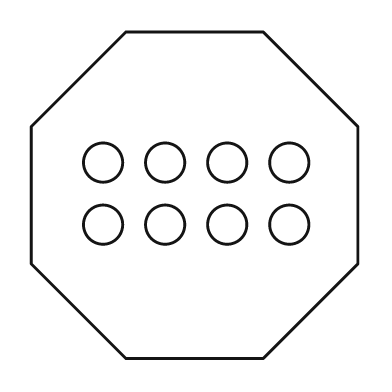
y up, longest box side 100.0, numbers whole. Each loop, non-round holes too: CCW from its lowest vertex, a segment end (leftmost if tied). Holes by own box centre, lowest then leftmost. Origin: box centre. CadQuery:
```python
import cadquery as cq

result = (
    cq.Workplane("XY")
    .moveTo(-21.0, -50.0)
    .lineTo(21.0, -50.0)
    .lineTo(50.0, -21.0)
    .lineTo(50.0, 21.0)
    .lineTo(21.0, 50.0)
    .lineTo(-21.0, 50.0)
    .lineTo(-50.0, 21.0)
    .lineTo(-50.0, -21.0)
    .close()
    .moveTo(-28.0, -9.0)
    .circle(6.0)
    .moveTo(-9.0, -9.0)
    .circle(6.0)
    .moveTo(10.0, -9.0)
    .circle(6.0)
    .moveTo(29.0, -9.0)
    .circle(6.0)
    .moveTo(-28.0, 10.0)
    .circle(6.0)
    .moveTo(-9.0, 10.0)
    .circle(6.0)
    .moveTo(10.0, 10.0)
    .circle(6.0)
    .moveTo(29.0, 10.0)
    .circle(6.0)
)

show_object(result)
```